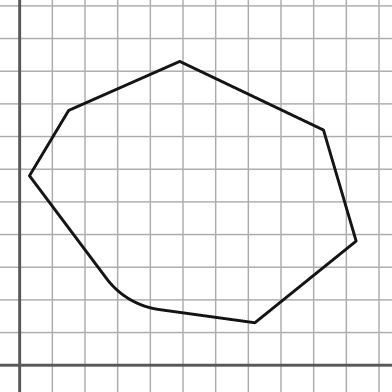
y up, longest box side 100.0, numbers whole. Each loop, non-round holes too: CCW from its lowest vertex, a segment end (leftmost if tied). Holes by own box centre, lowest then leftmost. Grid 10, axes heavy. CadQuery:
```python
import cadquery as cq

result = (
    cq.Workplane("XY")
    .moveTo(72.0, 13.0)
    .lineTo(103.0, 38.0)
    .lineTo(93.0, 72.0)
    .lineTo(49.0, 93.0)
    .lineTo(15.0, 78.0)
    .lineTo(3.0, 58.0)
    .lineTo(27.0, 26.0)
    .threePointArc((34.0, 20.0), (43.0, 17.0))
    .close()
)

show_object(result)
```